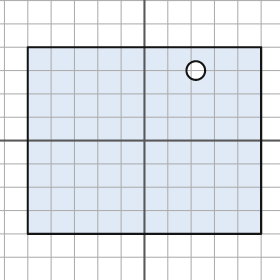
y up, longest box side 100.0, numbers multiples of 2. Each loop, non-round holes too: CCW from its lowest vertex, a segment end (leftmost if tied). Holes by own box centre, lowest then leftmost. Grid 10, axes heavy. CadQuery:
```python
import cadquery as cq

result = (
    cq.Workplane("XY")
    .moveTo(-50.0, -40.0)
    .lineTo(50.0, -40.0)
    .lineTo(50.0, 40.0)
    .lineTo(-50.0, 40.0)
    .close()
    .moveTo(22.0, 30.0)
    .circle(4.0)
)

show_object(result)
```